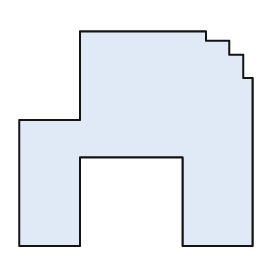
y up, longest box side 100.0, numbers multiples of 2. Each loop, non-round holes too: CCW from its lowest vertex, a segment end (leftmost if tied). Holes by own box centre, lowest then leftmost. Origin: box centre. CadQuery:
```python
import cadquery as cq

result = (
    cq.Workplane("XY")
    .moveTo(-50.0, -46.0)
    .lineTo(-24.0, -46.0)
    .lineTo(-24.0, -8.0)
    .lineTo(20.0, -8.0)
    .lineTo(20.0, -46.0)
    .lineTo(50.0, -46.0)
    .lineTo(50.0, 26.0)
    .lineTo(46.0, 26.0)
    .lineTo(46.0, 36.0)
    .lineTo(40.0, 36.0)
    .lineTo(40.0, 42.0)
    .lineTo(30.0, 42.0)
    .lineTo(30.0, 46.0)
    .lineTo(-24.0, 46.0)
    .lineTo(-24.0, 8.0)
    .lineTo(-50.0, 8.0)
    .close()
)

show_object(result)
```